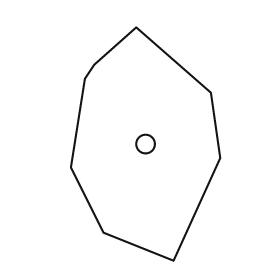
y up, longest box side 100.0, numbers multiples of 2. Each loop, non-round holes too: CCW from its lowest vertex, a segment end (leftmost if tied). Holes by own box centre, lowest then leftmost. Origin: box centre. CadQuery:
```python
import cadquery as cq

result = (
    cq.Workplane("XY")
    .moveTo(12.0, -50.0)
    .lineTo(32.0, -6.0)
    .lineTo(28.0, 22.0)
    .lineTo(-4.0, 50.0)
    .lineTo(-22.0, 34.0)
    .lineTo(-26.0, 28.0)
    .lineTo(-32.0, -10.0)
    .lineTo(-18.0, -38.0)
    .close()
    .moveTo(0.0, 0.0)
    .circle(4.0)
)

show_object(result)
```